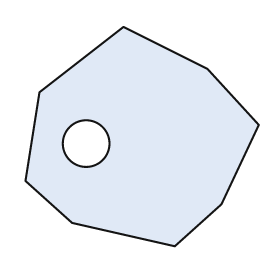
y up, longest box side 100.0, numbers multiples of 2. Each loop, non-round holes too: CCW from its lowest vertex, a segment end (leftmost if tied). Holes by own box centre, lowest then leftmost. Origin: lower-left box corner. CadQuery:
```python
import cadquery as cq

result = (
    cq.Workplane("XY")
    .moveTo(64.0, 0.0)
    .lineTo(84.0, 18.0)
    .lineTo(100.0, 52.0)
    .lineTo(78.0, 76.0)
    .lineTo(42.0, 94.0)
    .lineTo(6.0, 66.0)
    .lineTo(0.0, 28.0)
    .lineTo(20.0, 10.0)
    .close()
    .moveTo(26.0, 44.0)
    .circle(10.0)
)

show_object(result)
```